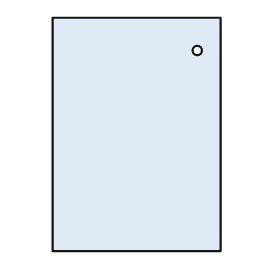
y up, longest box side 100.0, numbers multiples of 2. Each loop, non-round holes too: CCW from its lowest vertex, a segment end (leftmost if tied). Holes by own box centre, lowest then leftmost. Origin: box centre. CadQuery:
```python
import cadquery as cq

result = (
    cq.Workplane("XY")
    .moveTo(-36.0, -50.0)
    .lineTo(36.0, -50.0)
    .lineTo(36.0, 50.0)
    .lineTo(-36.0, 50.0)
    .close()
    .moveTo(26.0, 36.0)
    .circle(2.0)
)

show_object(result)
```